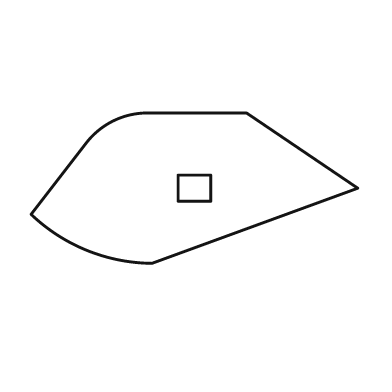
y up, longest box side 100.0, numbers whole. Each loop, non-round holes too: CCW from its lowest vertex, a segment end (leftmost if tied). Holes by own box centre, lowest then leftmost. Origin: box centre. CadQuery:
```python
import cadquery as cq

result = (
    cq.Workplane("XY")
    .moveTo(-13.0, -23.0)
    .lineTo(50.0, 0.0)
    .lineTo(16.0, 23.0)
    .lineTo(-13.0, 23.0)
    .threePointArc((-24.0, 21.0), (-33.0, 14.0))
    .lineTo(-50.0, -8.0)
    .threePointArc((-33.0, -19.0), (-13.0, -23.0))
    .close()
    .moveTo(-5.0, -4.0)
    .lineTo(5.0, -4.0)
    .lineTo(5.0, 4.0)
    .lineTo(-5.0, 4.0)
    .close()
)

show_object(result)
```